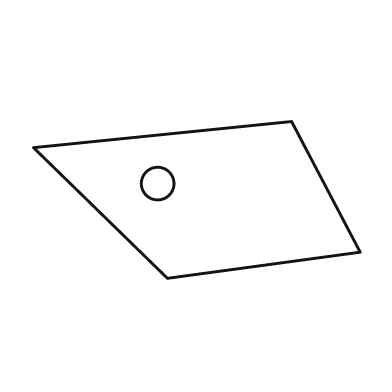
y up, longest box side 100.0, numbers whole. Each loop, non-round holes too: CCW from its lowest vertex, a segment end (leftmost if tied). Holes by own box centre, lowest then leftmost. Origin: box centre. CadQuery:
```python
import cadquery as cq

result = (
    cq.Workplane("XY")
    .moveTo(-9.0, -24.0)
    .lineTo(50.0, -16.0)
    .lineTo(29.0, 24.0)
    .lineTo(-50.0, 16.0)
    .close()
    .moveTo(-12.0, 5.0)
    .circle(5.0)
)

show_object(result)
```